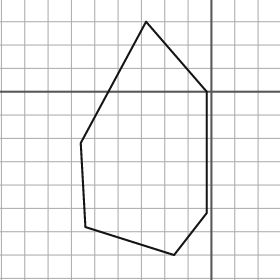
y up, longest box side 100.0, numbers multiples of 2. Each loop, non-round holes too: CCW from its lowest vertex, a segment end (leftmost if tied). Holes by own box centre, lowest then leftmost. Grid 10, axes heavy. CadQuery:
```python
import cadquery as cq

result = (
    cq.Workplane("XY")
    .moveTo(-16.0, -70.0)
    .lineTo(-2.0, -52.0)
    .lineTo(-2.0, 0.0)
    .lineTo(-28.0, 30.0)
    .lineTo(-56.0, -22.0)
    .lineTo(-54.0, -58.0)
    .close()
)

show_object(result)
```